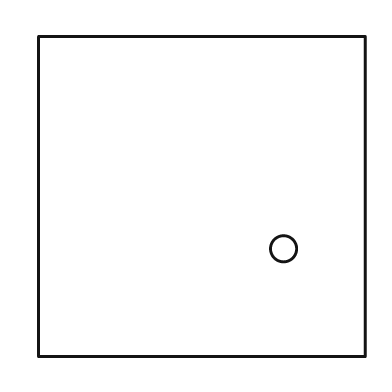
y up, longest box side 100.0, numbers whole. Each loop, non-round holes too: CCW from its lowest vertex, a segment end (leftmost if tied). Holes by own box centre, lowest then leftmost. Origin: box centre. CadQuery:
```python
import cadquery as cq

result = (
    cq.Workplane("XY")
    .moveTo(-50.0, -49.0)
    .lineTo(50.0, -49.0)
    .lineTo(50.0, 49.0)
    .lineTo(-50.0, 49.0)
    .close()
    .moveTo(25.0, -16.0)
    .circle(4.0)
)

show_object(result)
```